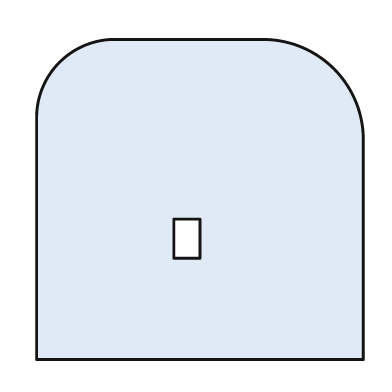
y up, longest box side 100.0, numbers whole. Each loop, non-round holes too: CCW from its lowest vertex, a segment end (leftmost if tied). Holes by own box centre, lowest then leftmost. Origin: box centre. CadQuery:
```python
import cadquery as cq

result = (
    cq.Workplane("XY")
    .moveTo(-50.0, -49.0)
    .lineTo(50.0, -49.0)
    .lineTo(50.0, 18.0)
    .threePointArc((41.0, 40.0), (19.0, 49.0))
    .lineTo(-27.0, 49.0)
    .threePointArc((-43.0, 42.0), (-50.0, 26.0))
    .close()
    .moveTo(-8.0, -18.0)
    .lineTo(0.0, -18.0)
    .lineTo(0.0, -6.0)
    .lineTo(-8.0, -6.0)
    .close()
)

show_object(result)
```